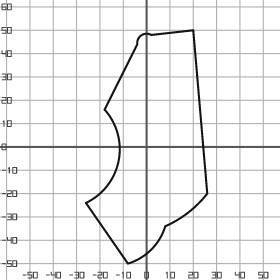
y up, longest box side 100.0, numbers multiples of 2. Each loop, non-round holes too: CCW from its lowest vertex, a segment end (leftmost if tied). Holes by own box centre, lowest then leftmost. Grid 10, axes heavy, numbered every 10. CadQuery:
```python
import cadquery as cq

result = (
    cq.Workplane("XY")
    .moveTo(-8.0, -50.0)
    .threePointArc((2.0, -44.0), (8.0, -34.0))
    .threePointArc((18.0, -28.0), (26.0, -20.0))
    .lineTo(20.0, 50.0)
    .lineTo(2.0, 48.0)
    .threePointArc((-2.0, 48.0), (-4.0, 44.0))
    .lineTo(-18.0, 16.0)
    .threePointArc((-12.0, -6.0), (-26.0, -24.0))
    .close()
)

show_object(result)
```